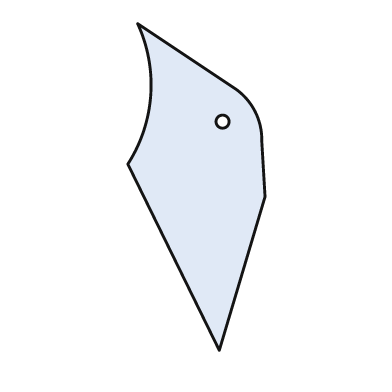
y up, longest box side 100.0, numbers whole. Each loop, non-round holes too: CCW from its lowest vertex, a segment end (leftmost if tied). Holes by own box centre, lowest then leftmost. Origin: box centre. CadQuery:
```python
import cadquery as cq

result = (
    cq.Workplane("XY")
    .moveTo(7.0, -50.0)
    .lineTo(21.0, -3.0)
    .lineTo(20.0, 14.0)
    .threePointArc((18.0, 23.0), (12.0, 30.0))
    .lineTo(-18.0, 50.0)
    .threePointArc((-14.0, 28.0), (-21.0, 7.0))
    .close()
    .moveTo(8.0, 20.0)
    .circle(2.0)
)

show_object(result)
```